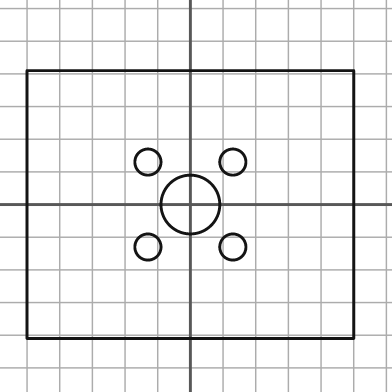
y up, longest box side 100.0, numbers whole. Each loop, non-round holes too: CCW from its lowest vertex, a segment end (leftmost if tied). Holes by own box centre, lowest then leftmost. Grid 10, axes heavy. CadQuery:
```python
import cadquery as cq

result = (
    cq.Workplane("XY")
    .moveTo(-50.0, -41.0)
    .lineTo(50.0, -41.0)
    .lineTo(50.0, 41.0)
    .lineTo(-50.0, 41.0)
    .close()
    .moveTo(-13.0, -13.0)
    .circle(4.0)
    .moveTo(13.0, -13.0)
    .circle(4.0)
    .moveTo(0.0, 0.0)
    .circle(9.0)
    .moveTo(-13.0, 13.0)
    .circle(4.0)
    .moveTo(13.0, 13.0)
    .circle(4.0)
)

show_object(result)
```